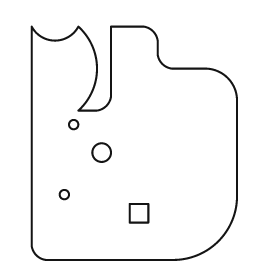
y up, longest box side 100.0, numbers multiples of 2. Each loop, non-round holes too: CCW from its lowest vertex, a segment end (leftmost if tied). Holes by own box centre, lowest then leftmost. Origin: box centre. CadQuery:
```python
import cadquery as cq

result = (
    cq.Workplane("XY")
    .moveTo(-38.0, -50.0)
    .lineTo(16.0, -50.0)
    .threePointArc((36.0, -42.0), (44.0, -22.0))
    .lineTo(44.0, 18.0)
    .threePointArc((40.0, 28.0), (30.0, 32.0))
    .lineTo(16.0, 32.0)
    .threePointArc((12.0, 34.0), (10.0, 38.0))
    .lineTo(10.0, 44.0)
    .threePointArc((8.0, 48.0), (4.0, 50.0))
    .lineTo(-10.0, 50.0)
    .lineTo(-10.0, 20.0)
    .threePointArc((-12.0, 16.0), (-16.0, 14.0))
    .lineTo(-24.0, 14.0)
    .threePointArc((-16.0, 32.0), (-24.0, 50.0))
    .threePointArc((-34.0, 44.0), (-44.0, 50.0))
    .lineTo(-44.0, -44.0)
    .threePointArc((-42.0, -48.0), (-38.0, -50.0))
    .close()
    .moveTo(-2.0, -34.0)
    .lineTo(6.0, -34.0)
    .lineTo(6.0, -26.0)
    .lineTo(-2.0, -26.0)
    .close()
    .moveTo(-30.0, -22.0)
    .circle(2.0)
    .moveTo(-14.0, -4.0)
    .circle(4.0)
    .moveTo(-26.0, 8.0)
    .circle(2.0)
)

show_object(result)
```